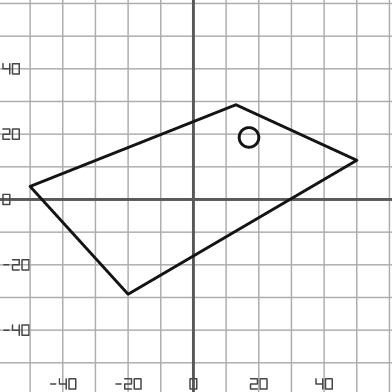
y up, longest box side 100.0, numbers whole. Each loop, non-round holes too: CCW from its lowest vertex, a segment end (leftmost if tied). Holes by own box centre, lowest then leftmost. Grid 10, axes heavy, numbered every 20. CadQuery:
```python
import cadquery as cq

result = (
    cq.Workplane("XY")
    .moveTo(-20.0, -29.0)
    .lineTo(50.0, 12.0)
    .lineTo(13.0, 29.0)
    .lineTo(-50.0, 4.0)
    .close()
    .moveTo(17.0, 19.0)
    .circle(3.0)
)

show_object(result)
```